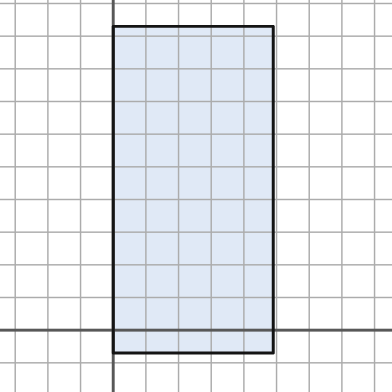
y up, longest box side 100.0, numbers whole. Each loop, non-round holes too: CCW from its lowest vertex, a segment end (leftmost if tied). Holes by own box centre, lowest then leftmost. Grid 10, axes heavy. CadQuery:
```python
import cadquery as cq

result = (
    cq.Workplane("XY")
    .moveTo(0.0, -7.0)
    .lineTo(49.0, -7.0)
    .lineTo(49.0, 93.0)
    .lineTo(0.0, 93.0)
    .close()
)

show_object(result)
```